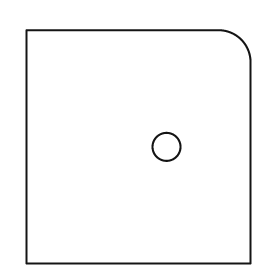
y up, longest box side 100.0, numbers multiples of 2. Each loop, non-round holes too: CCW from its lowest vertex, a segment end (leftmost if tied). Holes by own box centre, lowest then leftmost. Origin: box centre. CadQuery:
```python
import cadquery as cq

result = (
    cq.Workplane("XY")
    .moveTo(-48.0, -50.0)
    .lineTo(48.0, -50.0)
    .lineTo(48.0, 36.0)
    .threePointArc((44.0, 46.0), (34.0, 50.0))
    .lineTo(-48.0, 50.0)
    .close()
    .moveTo(12.0, 0.0)
    .circle(6.0)
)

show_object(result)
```